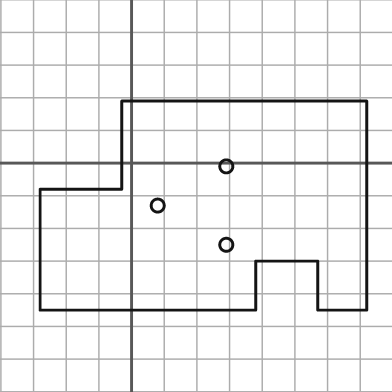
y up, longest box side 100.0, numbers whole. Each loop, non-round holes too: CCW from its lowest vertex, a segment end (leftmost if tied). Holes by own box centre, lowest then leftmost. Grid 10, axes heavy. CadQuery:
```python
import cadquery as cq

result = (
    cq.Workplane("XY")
    .moveTo(-28.0, -45.0)
    .lineTo(38.0, -45.0)
    .lineTo(38.0, -30.0)
    .lineTo(57.0, -30.0)
    .lineTo(57.0, -45.0)
    .lineTo(72.0, -45.0)
    .lineTo(72.0, 19.0)
    .lineTo(-3.0, 19.0)
    .lineTo(-3.0, -8.0)
    .lineTo(-28.0, -8.0)
    .close()
    .moveTo(29.0, -25.0)
    .circle(2.0)
    .moveTo(8.0, -13.0)
    .circle(2.0)
    .moveTo(29.0, -1.0)
    .circle(2.0)
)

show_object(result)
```